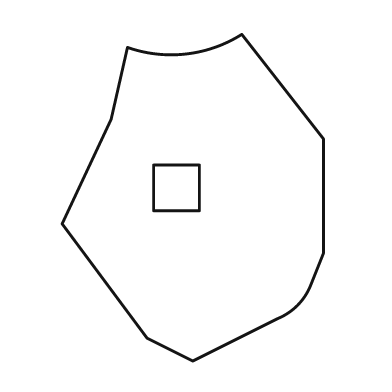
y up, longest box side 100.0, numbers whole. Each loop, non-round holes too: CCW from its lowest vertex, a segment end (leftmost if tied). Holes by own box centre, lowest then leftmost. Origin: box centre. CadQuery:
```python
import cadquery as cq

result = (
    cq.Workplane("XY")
    .moveTo(0.0, -50.0)
    .lineTo(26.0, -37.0)
    .threePointArc((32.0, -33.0), (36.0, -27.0))
    .lineTo(40.0, -17.0)
    .lineTo(40.0, 18.0)
    .lineTo(15.0, 50.0)
    .threePointArc((-2.0, 44.0), (-20.0, 46.0))
    .lineTo(-25.0, 24.0)
    .lineTo(-40.0, -8.0)
    .lineTo(-14.0, -43.0)
    .close()
    .moveTo(-12.0, -4.0)
    .lineTo(2.0, -4.0)
    .lineTo(2.0, 10.0)
    .lineTo(-12.0, 10.0)
    .close()
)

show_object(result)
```